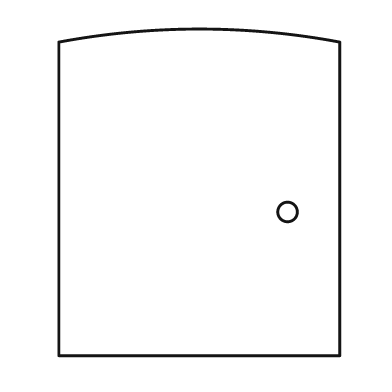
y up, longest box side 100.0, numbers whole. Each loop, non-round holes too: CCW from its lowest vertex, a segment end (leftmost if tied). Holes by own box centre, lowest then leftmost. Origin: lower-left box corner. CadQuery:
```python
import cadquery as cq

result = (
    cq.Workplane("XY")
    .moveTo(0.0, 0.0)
    .lineTo(86.0, 0.0)
    .lineTo(86.0, 96.0)
    .threePointArc((43.0, 100.0), (0.0, 96.0))
    .close()
    .moveTo(70.0, 44.0)
    .circle(3.0)
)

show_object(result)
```